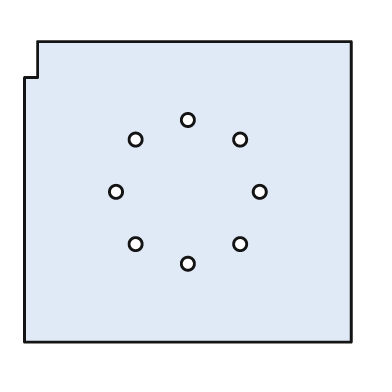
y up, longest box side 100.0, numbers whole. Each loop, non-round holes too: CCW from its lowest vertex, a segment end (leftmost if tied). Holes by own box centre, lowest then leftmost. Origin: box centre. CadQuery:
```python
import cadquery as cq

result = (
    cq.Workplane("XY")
    .moveTo(-50.0, -46.0)
    .lineTo(50.0, -46.0)
    .lineTo(50.0, 46.0)
    .lineTo(-46.0, 46.0)
    .lineTo(-46.0, 35.0)
    .lineTo(-50.0, 35.0)
    .close()
    .moveTo(0.0, -22.0)
    .circle(2.0)
    .moveTo(-16.0, -16.0)
    .circle(2.0)
    .moveTo(16.0, -16.0)
    .circle(2.0)
    .moveTo(-22.0, 0.0)
    .circle(2.0)
    .moveTo(22.0, 0.0)
    .circle(2.0)
    .moveTo(-16.0, 16.0)
    .circle(2.0)
    .moveTo(16.0, 16.0)
    .circle(2.0)
    .moveTo(0.0, 22.0)
    .circle(2.0)
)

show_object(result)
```